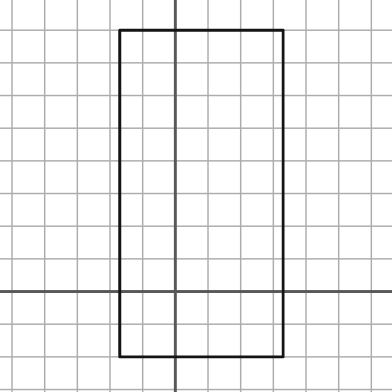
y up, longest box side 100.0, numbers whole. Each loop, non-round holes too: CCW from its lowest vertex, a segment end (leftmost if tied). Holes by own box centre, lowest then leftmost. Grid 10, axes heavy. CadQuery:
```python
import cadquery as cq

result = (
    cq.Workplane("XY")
    .moveTo(-17.0, -20.0)
    .lineTo(33.0, -20.0)
    .lineTo(33.0, 80.0)
    .lineTo(-17.0, 80.0)
    .close()
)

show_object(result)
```